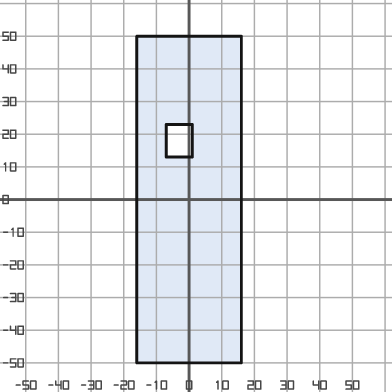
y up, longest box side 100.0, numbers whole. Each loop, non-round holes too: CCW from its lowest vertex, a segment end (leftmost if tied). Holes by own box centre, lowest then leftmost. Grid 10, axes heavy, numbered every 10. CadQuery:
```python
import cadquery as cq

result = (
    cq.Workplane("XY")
    .moveTo(-16.0, -50.0)
    .lineTo(16.0, -50.0)
    .lineTo(16.0, 50.0)
    .lineTo(-16.0, 50.0)
    .close()
    .moveTo(-7.0, 13.0)
    .lineTo(1.0, 13.0)
    .lineTo(1.0, 23.0)
    .lineTo(-7.0, 23.0)
    .close()
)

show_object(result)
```